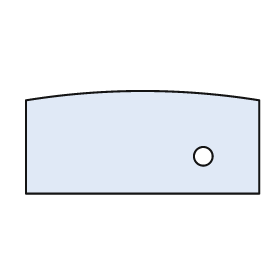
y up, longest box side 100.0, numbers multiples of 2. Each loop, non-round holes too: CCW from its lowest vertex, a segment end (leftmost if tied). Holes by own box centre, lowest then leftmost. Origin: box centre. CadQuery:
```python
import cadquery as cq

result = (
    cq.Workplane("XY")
    .moveTo(-50.0, -22.0)
    .lineTo(50.0, -22.0)
    .lineTo(50.0, 18.0)
    .threePointArc((0.0, 22.0), (-50.0, 18.0))
    .close()
    .moveTo(26.0, -6.0)
    .circle(4.0)
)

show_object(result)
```